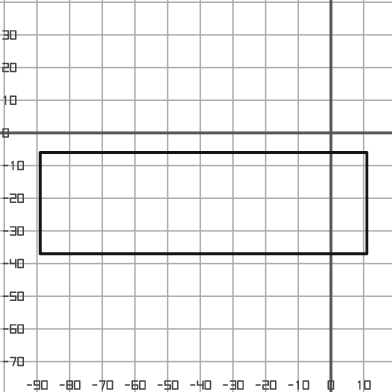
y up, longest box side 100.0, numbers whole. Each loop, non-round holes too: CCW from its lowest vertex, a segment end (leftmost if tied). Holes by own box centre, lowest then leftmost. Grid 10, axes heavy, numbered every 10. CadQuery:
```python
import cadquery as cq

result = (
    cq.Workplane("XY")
    .moveTo(-89.0, -37.0)
    .lineTo(11.0, -37.0)
    .lineTo(11.0, -6.0)
    .lineTo(-89.0, -6.0)
    .close()
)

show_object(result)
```